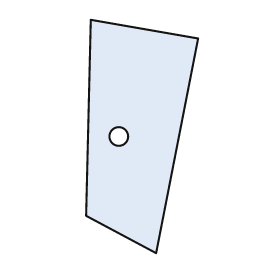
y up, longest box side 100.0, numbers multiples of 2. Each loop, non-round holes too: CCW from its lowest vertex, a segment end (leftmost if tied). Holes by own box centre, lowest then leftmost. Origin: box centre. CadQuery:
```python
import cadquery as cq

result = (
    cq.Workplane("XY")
    .moveTo(6.0, -50.0)
    .lineTo(24.0, 42.0)
    .lineTo(-22.0, 50.0)
    .lineTo(-24.0, -34.0)
    .close()
    .moveTo(-10.0, 0.0)
    .circle(4.0)
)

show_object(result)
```